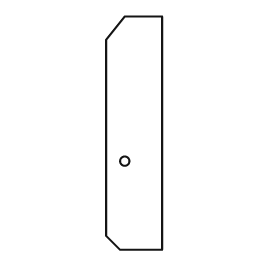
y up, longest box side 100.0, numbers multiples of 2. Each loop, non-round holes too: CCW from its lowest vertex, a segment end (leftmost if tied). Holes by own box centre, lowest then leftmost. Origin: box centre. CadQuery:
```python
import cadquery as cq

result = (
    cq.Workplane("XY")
    .moveTo(-6.0, -50.0)
    .lineTo(12.0, -50.0)
    .lineTo(12.0, 50.0)
    .lineTo(-4.0, 50.0)
    .lineTo(-12.0, 40.0)
    .lineTo(-12.0, -44.0)
    .close()
    .moveTo(-4.0, -12.0)
    .circle(2.0)
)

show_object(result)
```